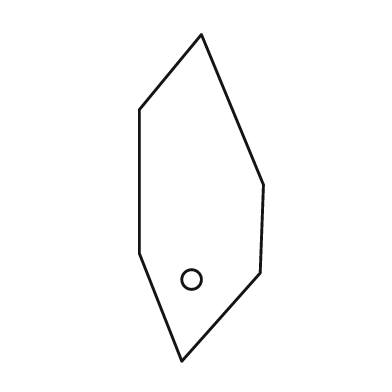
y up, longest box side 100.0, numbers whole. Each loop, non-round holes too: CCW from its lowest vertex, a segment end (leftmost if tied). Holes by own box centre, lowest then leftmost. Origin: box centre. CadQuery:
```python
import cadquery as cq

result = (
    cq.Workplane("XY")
    .moveTo(-6.0, -50.0)
    .lineTo(18.0, -23.0)
    .lineTo(19.0, 4.0)
    .lineTo(0.0, 50.0)
    .lineTo(-19.0, 27.0)
    .lineTo(-19.0, -17.0)
    .close()
    .moveTo(-3.0, -25.0)
    .circle(3.0)
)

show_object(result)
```